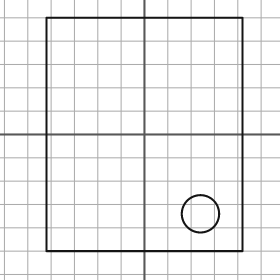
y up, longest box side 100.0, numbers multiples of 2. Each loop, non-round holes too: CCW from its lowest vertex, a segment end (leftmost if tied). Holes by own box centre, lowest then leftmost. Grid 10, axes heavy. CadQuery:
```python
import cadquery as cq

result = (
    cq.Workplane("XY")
    .moveTo(-42.0, -50.0)
    .lineTo(42.0, -50.0)
    .lineTo(42.0, 50.0)
    .lineTo(-42.0, 50.0)
    .close()
    .moveTo(24.0, -34.0)
    .circle(8.0)
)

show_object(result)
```